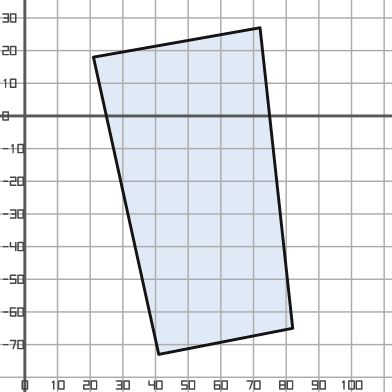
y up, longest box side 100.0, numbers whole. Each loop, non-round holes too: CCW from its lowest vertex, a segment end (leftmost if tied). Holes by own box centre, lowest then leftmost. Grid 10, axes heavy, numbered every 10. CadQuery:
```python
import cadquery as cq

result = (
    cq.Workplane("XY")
    .moveTo(41.0, -73.0)
    .lineTo(82.0, -65.0)
    .lineTo(72.0, 27.0)
    .lineTo(21.0, 18.0)
    .close()
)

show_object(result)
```